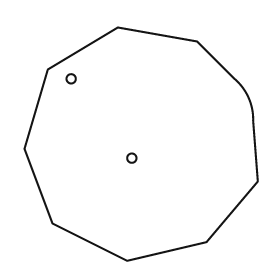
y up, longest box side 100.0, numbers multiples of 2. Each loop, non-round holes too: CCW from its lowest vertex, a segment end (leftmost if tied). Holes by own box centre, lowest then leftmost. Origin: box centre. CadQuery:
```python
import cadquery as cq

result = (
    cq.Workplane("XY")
    .moveTo(-6.0, -50.0)
    .lineTo(28.0, -42.0)
    .lineTo(50.0, -16.0)
    .lineTo(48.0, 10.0)
    .threePointArc((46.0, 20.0), (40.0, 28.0))
    .lineTo(24.0, 44.0)
    .lineTo(-10.0, 50.0)
    .lineTo(-40.0, 32.0)
    .lineTo(-50.0, -2.0)
    .lineTo(-38.0, -34.0)
    .close()
    .moveTo(-4.0, -6.0)
    .circle(2.0)
    .moveTo(-30.0, 28.0)
    .circle(2.0)
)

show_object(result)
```